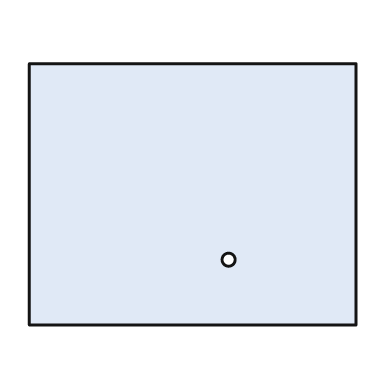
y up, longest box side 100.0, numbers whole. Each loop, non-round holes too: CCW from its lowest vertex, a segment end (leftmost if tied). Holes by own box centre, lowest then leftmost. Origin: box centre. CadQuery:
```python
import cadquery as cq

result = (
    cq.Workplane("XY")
    .moveTo(-50.0, -40.0)
    .lineTo(50.0, -40.0)
    .lineTo(50.0, 40.0)
    .lineTo(-50.0, 40.0)
    .close()
    .moveTo(11.0, -20.0)
    .circle(2.0)
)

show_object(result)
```